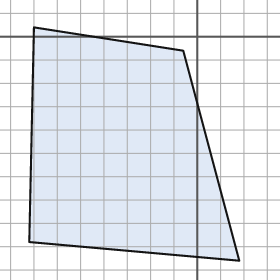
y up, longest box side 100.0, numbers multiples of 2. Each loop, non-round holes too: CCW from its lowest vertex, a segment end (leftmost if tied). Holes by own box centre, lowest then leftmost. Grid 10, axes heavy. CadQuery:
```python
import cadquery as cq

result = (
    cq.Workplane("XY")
    .moveTo(18.0, -96.0)
    .lineTo(-6.0, -6.0)
    .lineTo(-70.0, 4.0)
    .lineTo(-72.0, -88.0)
    .close()
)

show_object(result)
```